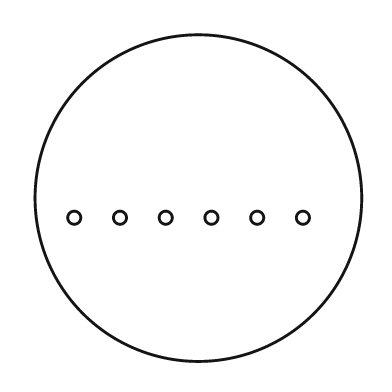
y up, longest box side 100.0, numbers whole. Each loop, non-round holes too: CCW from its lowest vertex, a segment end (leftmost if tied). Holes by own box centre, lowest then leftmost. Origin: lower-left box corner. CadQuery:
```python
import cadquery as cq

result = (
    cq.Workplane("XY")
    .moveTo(50.0, 50.0)
    .circle(50.0)
    .moveTo(12.0, 44.0)
    .circle(2.0)
    .moveTo(26.0, 44.0)
    .circle(2.0)
    .moveTo(40.0, 44.0)
    .circle(2.0)
    .moveTo(54.0, 44.0)
    .circle(2.0)
    .moveTo(68.0, 44.0)
    .circle(2.0)
    .moveTo(82.0, 44.0)
    .circle(2.0)
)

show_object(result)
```